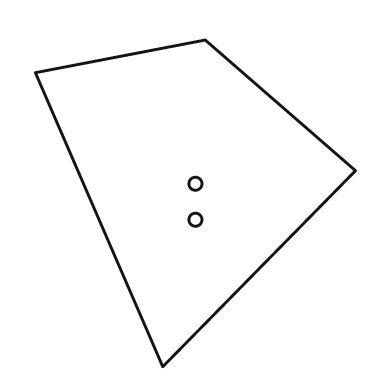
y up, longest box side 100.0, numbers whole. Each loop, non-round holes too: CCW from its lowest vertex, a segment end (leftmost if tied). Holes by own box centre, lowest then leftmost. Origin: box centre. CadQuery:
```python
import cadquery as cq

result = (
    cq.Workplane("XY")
    .moveTo(-10.0, -50.0)
    .lineTo(49.0, 10.0)
    .lineTo(3.0, 50.0)
    .lineTo(-49.0, 40.0)
    .close()
    .moveTo(0.0, -5.0)
    .circle(2.0)
    .moveTo(0.0, 6.0)
    .circle(2.0)
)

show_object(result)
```